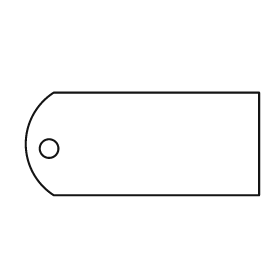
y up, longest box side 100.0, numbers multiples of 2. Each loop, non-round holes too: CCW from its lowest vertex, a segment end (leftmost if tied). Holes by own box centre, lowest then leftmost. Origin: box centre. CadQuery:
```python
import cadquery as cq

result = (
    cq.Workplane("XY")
    .moveTo(-38.0, -22.0)
    .lineTo(50.0, -22.0)
    .lineTo(50.0, 22.0)
    .lineTo(-38.0, 22.0)
    .threePointArc((-50.0, 0.0), (-38.0, -22.0))
    .close()
    .moveTo(-40.0, -2.0)
    .circle(4.0)
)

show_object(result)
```